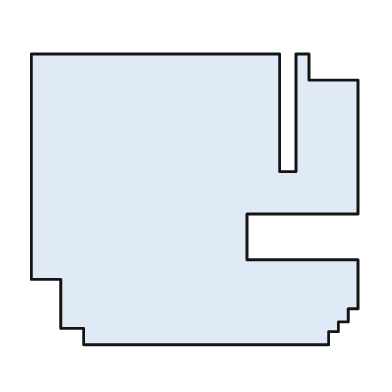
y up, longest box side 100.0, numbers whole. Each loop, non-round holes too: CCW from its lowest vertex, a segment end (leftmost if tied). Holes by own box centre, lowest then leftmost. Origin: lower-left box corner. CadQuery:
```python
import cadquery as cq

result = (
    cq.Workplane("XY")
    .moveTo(16.0, 0.0)
    .lineTo(91.0, 0.0)
    .lineTo(91.0, 4.0)
    .lineTo(94.0, 4.0)
    .lineTo(94.0, 7.0)
    .lineTo(97.0, 7.0)
    .lineTo(97.0, 11.0)
    .lineTo(100.0, 11.0)
    .lineTo(100.0, 26.0)
    .lineTo(66.0, 26.0)
    .lineTo(66.0, 40.0)
    .lineTo(100.0, 40.0)
    .lineTo(100.0, 81.0)
    .lineTo(85.0, 81.0)
    .lineTo(85.0, 89.0)
    .lineTo(81.0, 89.0)
    .lineTo(81.0, 53.0)
    .lineTo(76.0, 53.0)
    .lineTo(76.0, 89.0)
    .lineTo(0.0, 89.0)
    .lineTo(0.0, 20.0)
    .lineTo(9.0, 20.0)
    .lineTo(9.0, 5.0)
    .lineTo(16.0, 5.0)
    .close()
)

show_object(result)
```